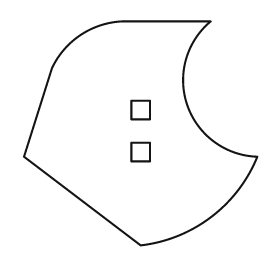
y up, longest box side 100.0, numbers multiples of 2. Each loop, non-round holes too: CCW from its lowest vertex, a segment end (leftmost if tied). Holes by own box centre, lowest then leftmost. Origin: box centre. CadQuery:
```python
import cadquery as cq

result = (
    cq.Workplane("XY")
    .moveTo(0.0, -48.0)
    .threePointArc((30.0, -36.0), (50.0, -10.0))
    .threePointArc((20.0, 12.0), (30.0, 48.0))
    .lineTo(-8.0, 48.0)
    .threePointArc((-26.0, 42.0), (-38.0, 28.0))
    .lineTo(-50.0, -10.0)
    .close()
    .moveTo(-4.0, -12.0)
    .lineTo(4.0, -12.0)
    .lineTo(4.0, -4.0)
    .lineTo(-4.0, -4.0)
    .close()
    .moveTo(-4.0, 6.0)
    .lineTo(4.0, 6.0)
    .lineTo(4.0, 14.0)
    .lineTo(-4.0, 14.0)
    .close()
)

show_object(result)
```